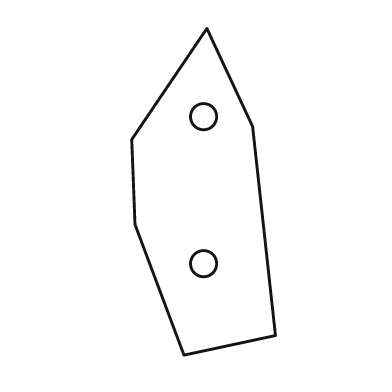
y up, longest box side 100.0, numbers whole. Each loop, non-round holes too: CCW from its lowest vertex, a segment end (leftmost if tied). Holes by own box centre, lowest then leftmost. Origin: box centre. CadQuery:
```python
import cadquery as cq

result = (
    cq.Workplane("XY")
    .moveTo(-6.0, -50.0)
    .lineTo(22.0, -44.0)
    .lineTo(15.0, 20.0)
    .lineTo(1.0, 50.0)
    .lineTo(-22.0, 16.0)
    .lineTo(-21.0, -10.0)
    .close()
    .moveTo(0.0, -22.0)
    .circle(4.0)
    .moveTo(0.0, 23.0)
    .circle(4.0)
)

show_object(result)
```